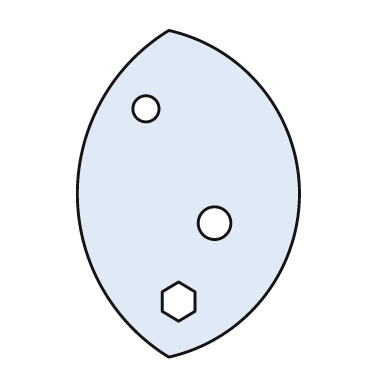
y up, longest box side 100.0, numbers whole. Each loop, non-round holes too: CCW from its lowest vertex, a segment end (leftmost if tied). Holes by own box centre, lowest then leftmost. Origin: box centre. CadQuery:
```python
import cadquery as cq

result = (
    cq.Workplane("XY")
    .moveTo(-6.0, -50.0)
    .threePointArc((34.0, 0.0), (-6.0, 50.0))
    .threePointArc((-34.0, 0.0), (-6.0, -50.0))
    .close()
    .moveTo(-3.0, -39.0)
    .lineTo(2.0, -36.0)
    .lineTo(2.0, -30.0)
    .lineTo(-3.0, -27.0)
    .lineTo(-8.0, -30.0)
    .lineTo(-8.0, -36.0)
    .close()
    .moveTo(8.0, -9.0)
    .circle(5.0)
    .moveTo(-13.0, 26.0)
    .circle(4.0)
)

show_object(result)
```